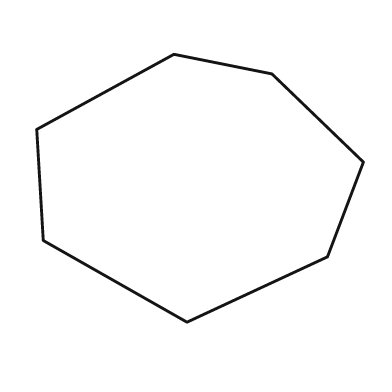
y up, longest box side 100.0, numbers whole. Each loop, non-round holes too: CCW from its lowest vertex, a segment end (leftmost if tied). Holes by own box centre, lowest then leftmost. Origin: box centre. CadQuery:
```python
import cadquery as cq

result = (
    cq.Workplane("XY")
    .moveTo(-4.0, -41.0)
    .lineTo(39.0, -21.0)
    .lineTo(50.0, 8.0)
    .lineTo(22.0, 35.0)
    .lineTo(-8.0, 41.0)
    .lineTo(-50.0, 18.0)
    .lineTo(-48.0, -16.0)
    .close()
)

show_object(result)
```